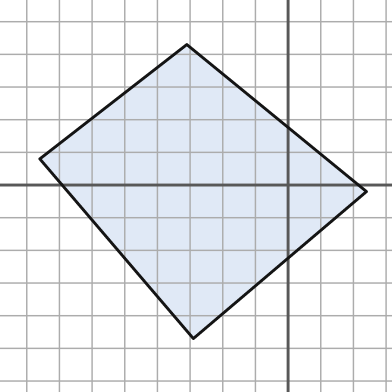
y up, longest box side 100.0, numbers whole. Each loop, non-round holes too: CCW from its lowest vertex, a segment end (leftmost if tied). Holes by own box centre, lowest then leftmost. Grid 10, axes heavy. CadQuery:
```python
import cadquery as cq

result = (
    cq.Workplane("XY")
    .moveTo(-29.0, -47.0)
    .lineTo(24.0, -2.0)
    .lineTo(-31.0, 43.0)
    .lineTo(-76.0, 8.0)
    .close()
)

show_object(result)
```